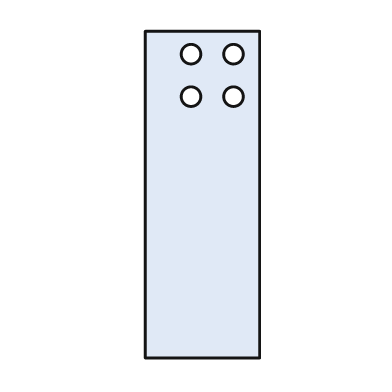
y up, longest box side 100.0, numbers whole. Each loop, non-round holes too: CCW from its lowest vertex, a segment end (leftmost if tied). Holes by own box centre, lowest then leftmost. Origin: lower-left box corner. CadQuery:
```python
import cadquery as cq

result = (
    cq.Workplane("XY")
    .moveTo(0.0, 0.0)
    .lineTo(35.0, 0.0)
    .lineTo(35.0, 100.0)
    .lineTo(0.0, 100.0)
    .close()
    .moveTo(14.0, 80.0)
    .circle(3.0)
    .moveTo(27.0, 80.0)
    .circle(3.0)
    .moveTo(14.0, 93.0)
    .circle(3.0)
    .moveTo(27.0, 93.0)
    .circle(3.0)
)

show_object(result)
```